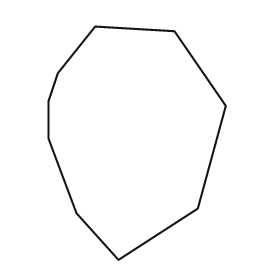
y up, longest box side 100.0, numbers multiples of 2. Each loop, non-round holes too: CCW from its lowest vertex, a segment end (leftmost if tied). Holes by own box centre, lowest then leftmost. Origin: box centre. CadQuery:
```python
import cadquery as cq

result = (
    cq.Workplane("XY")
    .moveTo(-8.0, -50.0)
    .lineTo(26.0, -28.0)
    .lineTo(38.0, 16.0)
    .lineTo(16.0, 48.0)
    .lineTo(-18.0, 50.0)
    .lineTo(-34.0, 30.0)
    .lineTo(-38.0, 18.0)
    .lineTo(-38.0, 2.0)
    .lineTo(-26.0, -30.0)
    .close()
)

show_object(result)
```